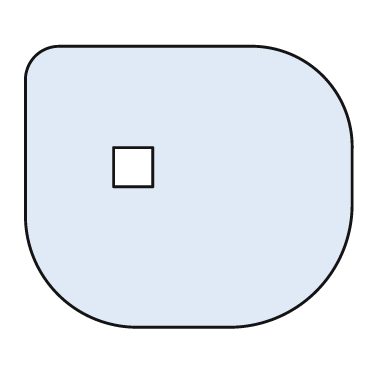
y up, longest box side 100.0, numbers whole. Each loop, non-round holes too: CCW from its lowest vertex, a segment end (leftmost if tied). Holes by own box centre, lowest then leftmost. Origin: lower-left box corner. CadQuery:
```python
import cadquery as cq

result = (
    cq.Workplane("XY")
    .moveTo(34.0, 0.0)
    .lineTo(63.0, 0.0)
    .threePointArc((89.0, 11.0), (100.0, 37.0))
    .lineTo(100.0, 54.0)
    .threePointArc((91.0, 77.0), (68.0, 86.0))
    .lineTo(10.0, 86.0)
    .threePointArc((3.0, 83.0), (0.0, 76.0))
    .lineTo(0.0, 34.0)
    .threePointArc((10.0, 10.0), (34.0, 0.0))
    .close()
    .moveTo(27.0, 43.0)
    .lineTo(39.0, 43.0)
    .lineTo(39.0, 55.0)
    .lineTo(27.0, 55.0)
    .close()
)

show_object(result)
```